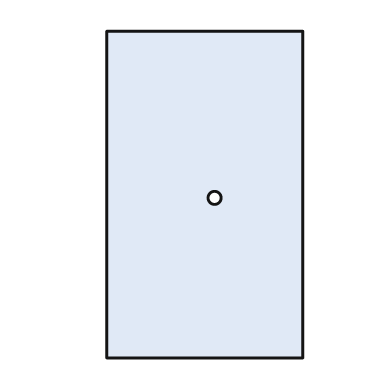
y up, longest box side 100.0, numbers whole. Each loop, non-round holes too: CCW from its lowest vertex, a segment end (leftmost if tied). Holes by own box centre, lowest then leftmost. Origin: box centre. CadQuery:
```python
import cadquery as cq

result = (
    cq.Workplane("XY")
    .moveTo(-30.0, -50.0)
    .lineTo(30.0, -50.0)
    .lineTo(30.0, 50.0)
    .lineTo(-30.0, 50.0)
    .close()
    .moveTo(3.0, -1.0)
    .circle(2.0)
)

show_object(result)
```